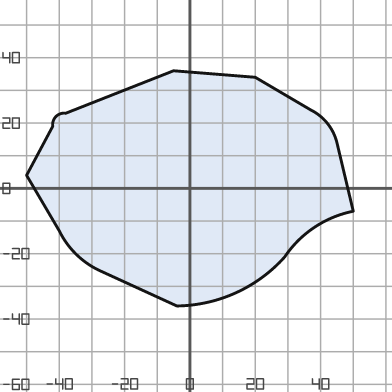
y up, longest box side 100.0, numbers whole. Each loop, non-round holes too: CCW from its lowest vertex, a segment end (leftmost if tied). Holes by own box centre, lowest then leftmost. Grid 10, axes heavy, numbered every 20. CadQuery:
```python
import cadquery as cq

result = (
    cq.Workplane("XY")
    .moveTo(-4.0, -36.0)
    .threePointArc((14.0, -32.0), (29.0, -21.0))
    .threePointArc((38.0, -12.0), (50.0, -7.0))
    .lineTo(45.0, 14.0)
    .threePointArc((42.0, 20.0), (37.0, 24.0))
    .lineTo(20.0, 34.0)
    .lineTo(-5.0, 36.0)
    .lineTo(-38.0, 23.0)
    .threePointArc((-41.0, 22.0), (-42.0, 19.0))
    .lineTo(-50.0, 4.0)
    .lineTo(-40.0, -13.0)
    .threePointArc((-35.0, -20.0), (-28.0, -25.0))
    .close()
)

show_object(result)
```